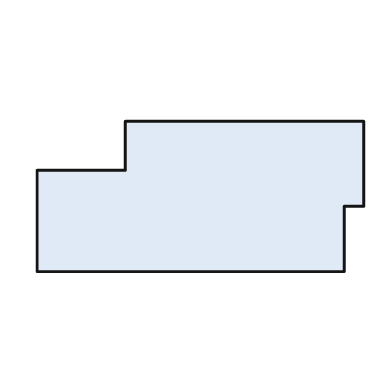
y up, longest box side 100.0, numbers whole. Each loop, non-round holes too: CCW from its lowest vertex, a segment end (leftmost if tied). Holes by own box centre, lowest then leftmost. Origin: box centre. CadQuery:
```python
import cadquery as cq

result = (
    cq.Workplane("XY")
    .moveTo(-50.0, -23.0)
    .lineTo(44.0, -23.0)
    .lineTo(44.0, -3.0)
    .lineTo(50.0, -3.0)
    .lineTo(50.0, 23.0)
    .lineTo(-23.0, 23.0)
    .lineTo(-23.0, 8.0)
    .lineTo(-50.0, 8.0)
    .close()
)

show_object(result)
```